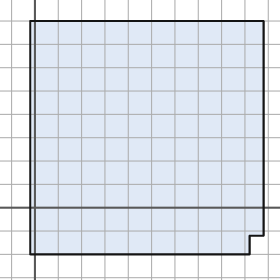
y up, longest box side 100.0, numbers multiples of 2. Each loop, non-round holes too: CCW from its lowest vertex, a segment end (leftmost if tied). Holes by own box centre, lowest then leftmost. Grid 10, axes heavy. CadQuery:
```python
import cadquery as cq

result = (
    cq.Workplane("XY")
    .moveTo(-2.0, -20.0)
    .lineTo(92.0, -20.0)
    .lineTo(92.0, -12.0)
    .lineTo(98.0, -12.0)
    .lineTo(98.0, 80.0)
    .lineTo(-2.0, 80.0)
    .close()
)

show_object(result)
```